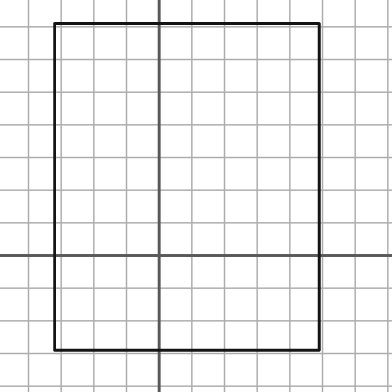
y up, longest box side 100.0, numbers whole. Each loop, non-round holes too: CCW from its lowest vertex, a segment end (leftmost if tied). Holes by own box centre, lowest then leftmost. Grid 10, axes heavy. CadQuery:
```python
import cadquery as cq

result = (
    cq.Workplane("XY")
    .moveTo(-32.0, -29.0)
    .lineTo(49.0, -29.0)
    .lineTo(49.0, 71.0)
    .lineTo(-32.0, 71.0)
    .close()
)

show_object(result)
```